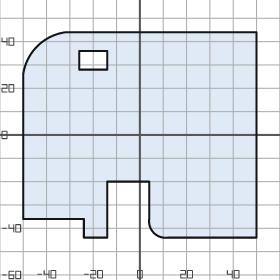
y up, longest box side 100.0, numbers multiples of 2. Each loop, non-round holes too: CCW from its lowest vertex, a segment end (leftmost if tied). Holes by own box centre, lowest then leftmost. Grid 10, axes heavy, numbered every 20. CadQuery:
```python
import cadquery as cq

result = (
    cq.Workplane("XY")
    .moveTo(-24.0, -44.0)
    .lineTo(-14.0, -44.0)
    .lineTo(-14.0, -20.0)
    .lineTo(4.0, -20.0)
    .lineTo(4.0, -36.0)
    .threePointArc((6.0, -42.0), (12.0, -44.0))
    .lineTo(50.0, -44.0)
    .lineTo(50.0, 44.0)
    .lineTo(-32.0, 44.0)
    .threePointArc((-44.0, 38.0), (-50.0, 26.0))
    .lineTo(-50.0, -36.0)
    .lineTo(-24.0, -36.0)
    .close()
    .moveTo(-26.0, 28.0)
    .lineTo(-14.0, 28.0)
    .lineTo(-14.0, 36.0)
    .lineTo(-26.0, 36.0)
    .close()
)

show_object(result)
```